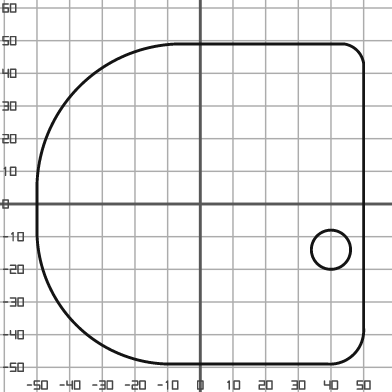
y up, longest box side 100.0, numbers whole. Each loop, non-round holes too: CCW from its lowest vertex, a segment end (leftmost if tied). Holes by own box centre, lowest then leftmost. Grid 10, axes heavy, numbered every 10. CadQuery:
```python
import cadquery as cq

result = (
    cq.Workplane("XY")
    .moveTo(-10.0, -49.0)
    .lineTo(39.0, -49.0)
    .threePointArc((47.0, -46.0), (50.0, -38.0))
    .lineTo(50.0, 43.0)
    .threePointArc((48.0, 47.0), (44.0, 49.0))
    .lineTo(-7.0, 49.0)
    .threePointArc((-37.0, 36.0), (-50.0, 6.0))
    .lineTo(-50.0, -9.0)
    .threePointArc((-38.0, -37.0), (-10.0, -49.0))
    .close()
    .moveTo(40.0, -14.0)
    .circle(6.0)
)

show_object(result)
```